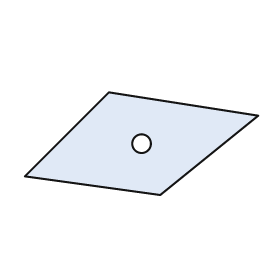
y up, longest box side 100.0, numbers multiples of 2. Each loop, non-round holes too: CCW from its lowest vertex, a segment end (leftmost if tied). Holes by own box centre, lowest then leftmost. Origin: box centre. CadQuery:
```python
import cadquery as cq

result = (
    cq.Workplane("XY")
    .moveTo(8.0, -22.0)
    .lineTo(50.0, 12.0)
    .lineTo(-14.0, 22.0)
    .lineTo(-50.0, -14.0)
    .close()
    .moveTo(0.0, 0.0)
    .circle(4.0)
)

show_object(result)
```